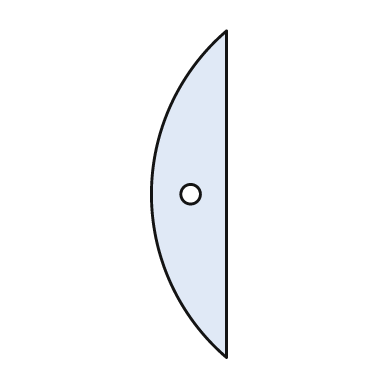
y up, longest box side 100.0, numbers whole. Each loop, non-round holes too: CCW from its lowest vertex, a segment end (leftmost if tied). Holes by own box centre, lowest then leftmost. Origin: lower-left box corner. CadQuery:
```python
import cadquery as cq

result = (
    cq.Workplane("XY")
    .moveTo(23.0, 0.0)
    .lineTo(23.0, 100.0)
    .threePointArc((0.0, 50.0), (23.0, 0.0))
    .close()
    .moveTo(12.0, 50.0)
    .circle(3.0)
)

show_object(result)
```